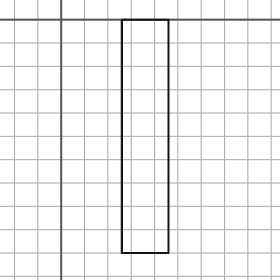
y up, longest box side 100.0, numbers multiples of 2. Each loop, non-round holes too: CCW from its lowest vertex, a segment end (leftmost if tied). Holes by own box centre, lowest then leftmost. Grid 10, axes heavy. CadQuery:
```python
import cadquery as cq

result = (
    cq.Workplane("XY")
    .moveTo(26.0, -100.0)
    .lineTo(46.0, -100.0)
    .lineTo(46.0, 0.0)
    .lineTo(26.0, 0.0)
    .close()
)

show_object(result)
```